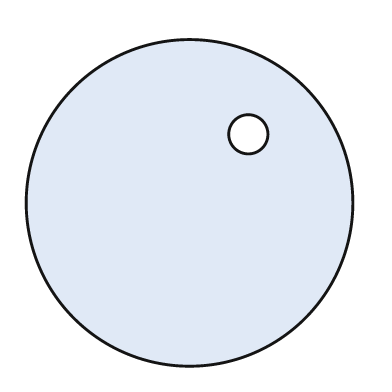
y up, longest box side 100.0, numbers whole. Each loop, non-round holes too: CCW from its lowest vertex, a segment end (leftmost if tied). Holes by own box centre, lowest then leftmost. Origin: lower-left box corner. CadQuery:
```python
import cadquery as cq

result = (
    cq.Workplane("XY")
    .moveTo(50.0, 50.0)
    .circle(50.0)
    .moveTo(68.0, 71.0)
    .circle(6.0)
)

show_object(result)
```